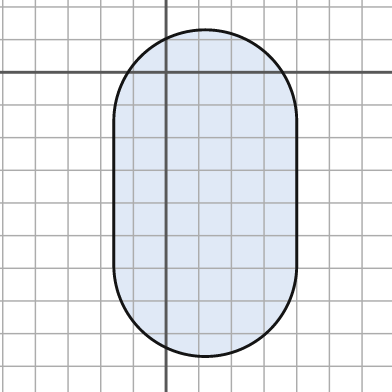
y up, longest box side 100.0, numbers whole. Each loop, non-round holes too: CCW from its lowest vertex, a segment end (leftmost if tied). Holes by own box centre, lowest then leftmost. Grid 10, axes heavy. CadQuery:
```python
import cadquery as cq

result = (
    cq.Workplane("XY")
    .moveTo(-16.0, -59.0)
    .threePointArc((12.0, -87.0), (40.0, -59.0))
    .lineTo(40.0, -15.0)
    .threePointArc((12.0, 13.0), (-16.0, -15.0))
    .close()
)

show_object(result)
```